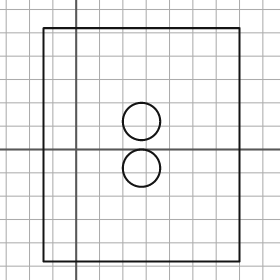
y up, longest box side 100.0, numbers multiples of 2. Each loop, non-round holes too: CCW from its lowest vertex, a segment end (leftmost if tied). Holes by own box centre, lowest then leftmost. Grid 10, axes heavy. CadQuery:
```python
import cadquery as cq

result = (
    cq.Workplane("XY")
    .moveTo(-14.0, -48.0)
    .lineTo(70.0, -48.0)
    .lineTo(70.0, 52.0)
    .lineTo(-14.0, 52.0)
    .close()
    .moveTo(28.0, -8.0)
    .circle(8.0)
    .moveTo(28.0, 12.0)
    .circle(8.0)
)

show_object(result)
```